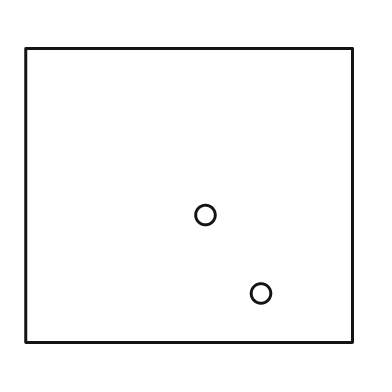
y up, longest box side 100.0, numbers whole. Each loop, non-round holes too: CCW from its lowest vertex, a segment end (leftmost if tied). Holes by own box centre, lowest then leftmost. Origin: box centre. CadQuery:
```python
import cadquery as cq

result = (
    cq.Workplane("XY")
    .moveTo(-50.0, -45.0)
    .lineTo(50.0, -45.0)
    .lineTo(50.0, 45.0)
    .lineTo(-50.0, 45.0)
    .close()
    .moveTo(22.0, -30.0)
    .circle(3.0)
    .moveTo(5.0, -6.0)
    .circle(3.0)
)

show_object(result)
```